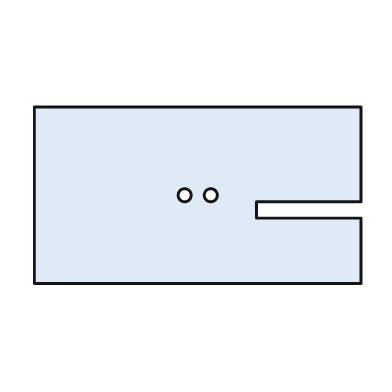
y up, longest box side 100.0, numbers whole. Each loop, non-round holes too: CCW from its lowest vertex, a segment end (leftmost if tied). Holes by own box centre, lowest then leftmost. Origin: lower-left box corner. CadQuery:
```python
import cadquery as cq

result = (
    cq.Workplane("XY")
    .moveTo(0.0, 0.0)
    .lineTo(100.0, 0.0)
    .lineTo(100.0, 20.0)
    .lineTo(68.0, 20.0)
    .lineTo(68.0, 25.0)
    .lineTo(100.0, 25.0)
    .lineTo(100.0, 54.0)
    .lineTo(0.0, 54.0)
    .close()
    .moveTo(46.0, 27.0)
    .circle(2.0)
    .moveTo(54.0, 27.0)
    .circle(2.0)
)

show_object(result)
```